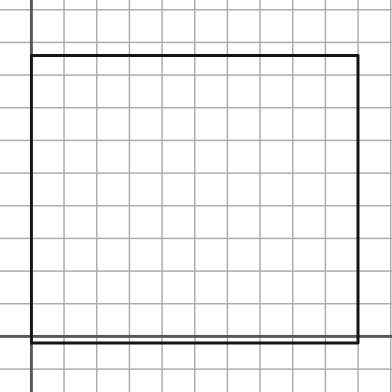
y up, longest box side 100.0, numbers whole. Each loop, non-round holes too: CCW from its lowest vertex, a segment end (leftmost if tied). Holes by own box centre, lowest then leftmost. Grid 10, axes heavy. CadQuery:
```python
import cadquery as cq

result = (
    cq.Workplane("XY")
    .moveTo(0.0, -2.0)
    .lineTo(100.0, -2.0)
    .lineTo(100.0, 86.0)
    .lineTo(0.0, 86.0)
    .close()
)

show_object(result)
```